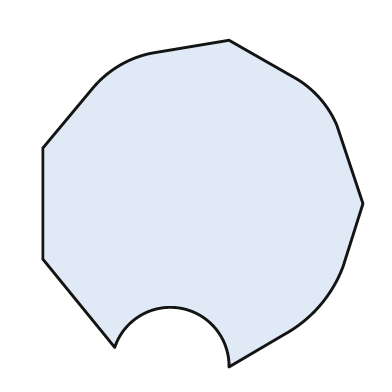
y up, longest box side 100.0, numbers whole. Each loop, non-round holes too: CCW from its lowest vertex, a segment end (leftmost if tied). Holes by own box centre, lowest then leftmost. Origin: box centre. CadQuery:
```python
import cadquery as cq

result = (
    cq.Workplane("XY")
    .moveTo(8.0, -50.0)
    .lineTo(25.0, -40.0)
    .threePointArc((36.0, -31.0), (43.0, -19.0))
    .lineTo(49.0, 0.0)
    .lineTo(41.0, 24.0)
    .threePointArc((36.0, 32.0), (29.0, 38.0))
    .lineTo(8.0, 50.0)
    .lineTo(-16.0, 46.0)
    .threePointArc((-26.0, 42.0), (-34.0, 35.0))
    .lineTo(-49.0, 17.0)
    .lineTo(-49.0, -17.0)
    .lineTo(-27.0, -44.0)
    .threePointArc((-7.0, -32.0), (8.0, -50.0))
    .close()
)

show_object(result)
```